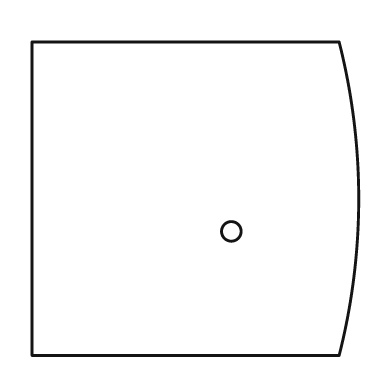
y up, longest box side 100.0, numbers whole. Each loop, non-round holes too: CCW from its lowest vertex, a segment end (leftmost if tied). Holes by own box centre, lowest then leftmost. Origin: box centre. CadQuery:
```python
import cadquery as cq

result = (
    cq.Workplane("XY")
    .moveTo(-50.0, -48.0)
    .lineTo(44.0, -48.0)
    .threePointArc((50.0, 0.0), (44.0, 48.0))
    .lineTo(-50.0, 48.0)
    .close()
    .moveTo(11.0, -10.0)
    .circle(3.0)
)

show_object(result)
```